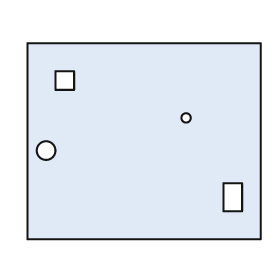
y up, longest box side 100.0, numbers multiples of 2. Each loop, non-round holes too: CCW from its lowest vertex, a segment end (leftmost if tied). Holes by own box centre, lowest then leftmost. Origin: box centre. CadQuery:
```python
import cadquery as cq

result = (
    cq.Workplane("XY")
    .moveTo(-50.0, -42.0)
    .lineTo(50.0, -42.0)
    .lineTo(50.0, 42.0)
    .lineTo(-50.0, 42.0)
    .close()
    .moveTo(34.0, -30.0)
    .lineTo(42.0, -30.0)
    .lineTo(42.0, -18.0)
    .lineTo(34.0, -18.0)
    .close()
    .moveTo(-42.0, -4.0)
    .circle(4.0)
    .moveTo(18.0, 10.0)
    .circle(2.0)
    .moveTo(-38.0, 22.0)
    .lineTo(-30.0, 22.0)
    .lineTo(-30.0, 30.0)
    .lineTo(-38.0, 30.0)
    .close()
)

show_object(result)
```